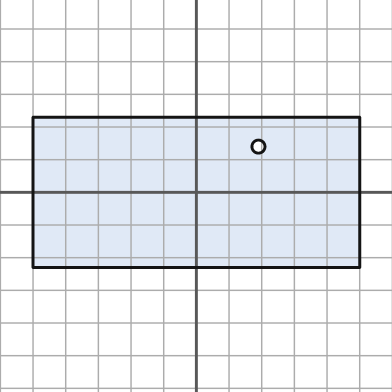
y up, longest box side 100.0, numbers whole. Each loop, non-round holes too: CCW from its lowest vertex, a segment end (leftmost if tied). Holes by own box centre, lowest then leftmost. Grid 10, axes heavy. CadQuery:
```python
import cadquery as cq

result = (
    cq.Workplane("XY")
    .moveTo(-50.0, -23.0)
    .lineTo(50.0, -23.0)
    .lineTo(50.0, 23.0)
    .lineTo(-50.0, 23.0)
    .close()
    .moveTo(19.0, 14.0)
    .circle(2.0)
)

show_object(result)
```